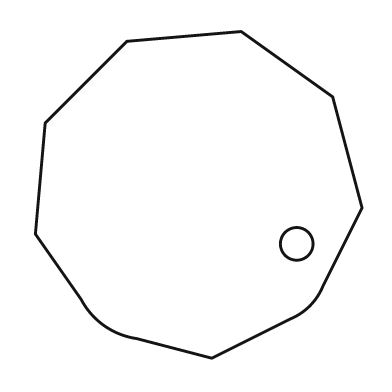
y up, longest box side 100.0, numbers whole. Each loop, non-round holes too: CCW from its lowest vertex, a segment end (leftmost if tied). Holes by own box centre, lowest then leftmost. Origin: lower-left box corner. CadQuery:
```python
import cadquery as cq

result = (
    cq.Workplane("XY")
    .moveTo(54.0, 0.0)
    .lineTo(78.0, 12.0)
    .threePointArc((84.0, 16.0), (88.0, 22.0))
    .lineTo(100.0, 46.0)
    .lineTo(91.0, 80.0)
    .lineTo(63.0, 100.0)
    .lineTo(28.0, 97.0)
    .lineTo(3.0, 72.0)
    .lineTo(0.0, 38.0)
    .lineTo(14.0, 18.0)
    .threePointArc((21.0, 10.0), (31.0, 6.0))
    .close()
    .moveTo(80.0, 35.0)
    .circle(5.0)
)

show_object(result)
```